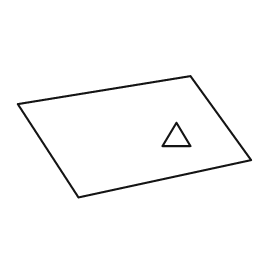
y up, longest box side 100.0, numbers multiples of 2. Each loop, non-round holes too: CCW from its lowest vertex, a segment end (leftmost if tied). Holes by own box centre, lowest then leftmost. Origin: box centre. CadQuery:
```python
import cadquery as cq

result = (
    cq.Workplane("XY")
    .moveTo(-24.0, -26.0)
    .lineTo(50.0, -10.0)
    .lineTo(24.0, 26.0)
    .lineTo(-50.0, 14.0)
    .close()
    .moveTo(12.0, -4.0)
    .lineTo(24.0, -4.0)
    .lineTo(18.0, 6.0)
    .close()
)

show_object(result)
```